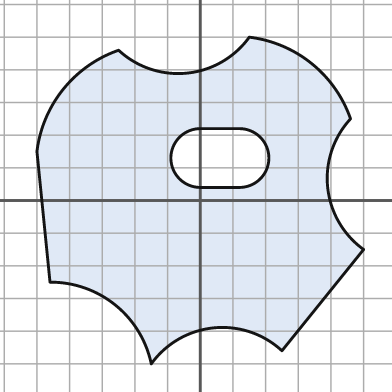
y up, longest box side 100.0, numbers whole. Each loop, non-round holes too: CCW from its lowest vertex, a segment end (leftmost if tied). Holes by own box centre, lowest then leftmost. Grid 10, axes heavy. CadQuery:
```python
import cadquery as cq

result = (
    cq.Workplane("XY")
    .moveTo(-15.0, -50.0)
    .threePointArc((4.0, -39.0), (25.0, -46.0))
    .lineTo(50.0, -15.0)
    .threePointArc((39.0, 4.0), (46.0, 25.0))
    .threePointArc((34.0, 42.0), (15.0, 50.0))
    .threePointArc((-4.0, 39.0), (-25.0, 46.0))
    .threePointArc((-42.0, 34.0), (-50.0, 15.0))
    .lineTo(-46.0, -25.0)
    .threePointArc((-26.0, -32.0), (-15.0, -50.0))
    .close()
    .moveTo(0.0, 4.0)
    .lineTo(12.0, 4.0)
    .threePointArc((21.0, 13.0), (12.0, 22.0))
    .lineTo(0.0, 22.0)
    .threePointArc((-9.0, 13.0), (0.0, 4.0))
    .close()
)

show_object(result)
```